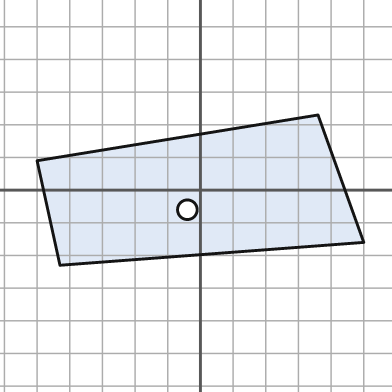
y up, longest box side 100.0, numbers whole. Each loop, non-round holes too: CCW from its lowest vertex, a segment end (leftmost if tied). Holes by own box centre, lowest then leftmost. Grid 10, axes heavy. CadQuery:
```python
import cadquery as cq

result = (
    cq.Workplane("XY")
    .moveTo(-43.0, -23.0)
    .lineTo(50.0, -16.0)
    .lineTo(36.0, 23.0)
    .lineTo(-50.0, 9.0)
    .close()
    .moveTo(-4.0, -6.0)
    .circle(3.0)
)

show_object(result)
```